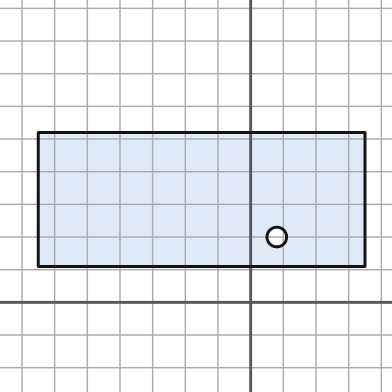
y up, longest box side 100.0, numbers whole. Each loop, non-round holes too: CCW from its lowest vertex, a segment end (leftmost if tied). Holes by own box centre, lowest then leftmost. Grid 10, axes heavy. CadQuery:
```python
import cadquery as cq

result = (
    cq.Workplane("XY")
    .moveTo(-65.0, 11.0)
    .lineTo(35.0, 11.0)
    .lineTo(35.0, 52.0)
    .lineTo(-65.0, 52.0)
    .close()
    .moveTo(8.0, 20.0)
    .circle(3.0)
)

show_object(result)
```